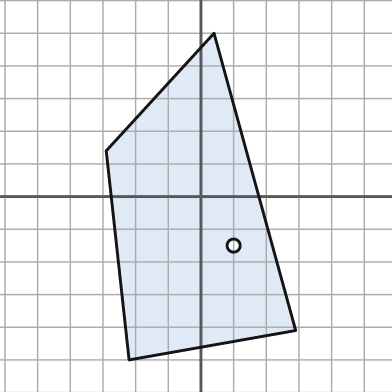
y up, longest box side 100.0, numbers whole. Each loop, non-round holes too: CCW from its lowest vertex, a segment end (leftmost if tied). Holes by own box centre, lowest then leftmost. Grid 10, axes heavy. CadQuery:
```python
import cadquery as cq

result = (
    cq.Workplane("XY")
    .moveTo(-22.0, -50.0)
    .lineTo(29.0, -41.0)
    .lineTo(4.0, 50.0)
    .lineTo(-29.0, 14.0)
    .close()
    .moveTo(10.0, -15.0)
    .circle(2.0)
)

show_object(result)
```